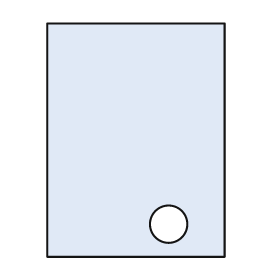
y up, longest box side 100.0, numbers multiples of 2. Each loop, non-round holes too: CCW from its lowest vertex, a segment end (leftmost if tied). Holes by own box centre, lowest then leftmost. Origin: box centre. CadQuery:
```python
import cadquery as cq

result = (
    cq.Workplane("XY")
    .moveTo(-38.0, -50.0)
    .lineTo(38.0, -50.0)
    .lineTo(38.0, 50.0)
    .lineTo(-38.0, 50.0)
    .close()
    .moveTo(14.0, -36.0)
    .circle(8.0)
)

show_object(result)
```